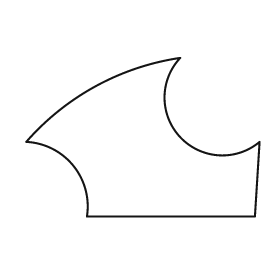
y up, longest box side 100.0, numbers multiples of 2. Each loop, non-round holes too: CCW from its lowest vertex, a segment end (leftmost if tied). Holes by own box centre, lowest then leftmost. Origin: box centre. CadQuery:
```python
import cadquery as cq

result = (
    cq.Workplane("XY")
    .moveTo(-24.0, -34.0)
    .lineTo(48.0, -34.0)
    .lineTo(50.0, -2.0)
    .threePointArc((16.0, 0.0), (16.0, 34.0))
    .threePointArc((-20.0, 22.0), (-50.0, -2.0))
    .threePointArc((-30.0, -12.0), (-24.0, -34.0))
    .close()
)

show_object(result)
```